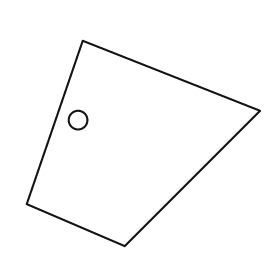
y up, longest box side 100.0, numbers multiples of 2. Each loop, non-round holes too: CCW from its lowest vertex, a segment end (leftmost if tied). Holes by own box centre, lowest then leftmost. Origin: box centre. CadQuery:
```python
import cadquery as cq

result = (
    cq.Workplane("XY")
    .moveTo(-8.0, -44.0)
    .lineTo(50.0, 14.0)
    .lineTo(-26.0, 44.0)
    .lineTo(-50.0, -26.0)
    .close()
    .moveTo(-28.0, 10.0)
    .circle(4.0)
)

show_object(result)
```